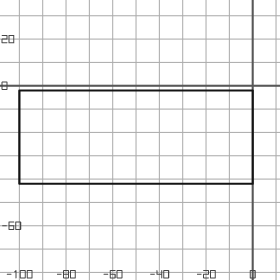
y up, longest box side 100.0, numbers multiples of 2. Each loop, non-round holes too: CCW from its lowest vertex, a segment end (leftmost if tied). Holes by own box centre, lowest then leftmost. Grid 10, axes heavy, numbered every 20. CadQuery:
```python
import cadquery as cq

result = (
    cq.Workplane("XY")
    .moveTo(-100.0, -42.0)
    .lineTo(0.0, -42.0)
    .lineTo(0.0, -2.0)
    .lineTo(-100.0, -2.0)
    .close()
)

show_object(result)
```